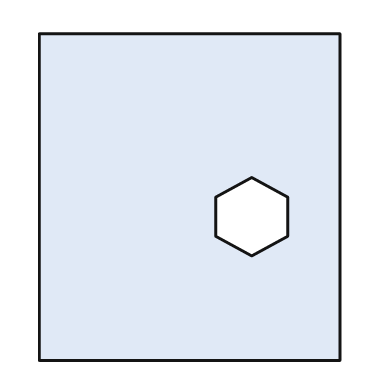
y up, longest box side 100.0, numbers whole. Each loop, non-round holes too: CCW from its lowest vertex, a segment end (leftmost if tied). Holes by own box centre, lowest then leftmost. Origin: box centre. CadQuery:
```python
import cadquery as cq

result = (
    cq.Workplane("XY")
    .moveTo(-46.0, -50.0)
    .lineTo(46.0, -50.0)
    .lineTo(46.0, 50.0)
    .lineTo(-46.0, 50.0)
    .close()
    .moveTo(19.0, -18.0)
    .lineTo(30.0, -12.0)
    .lineTo(30.0, 0.0)
    .lineTo(19.0, 6.0)
    .lineTo(8.0, 0.0)
    .lineTo(8.0, -12.0)
    .close()
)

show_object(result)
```